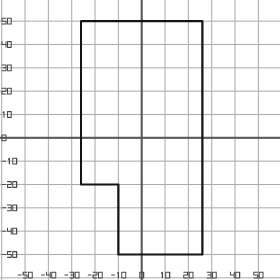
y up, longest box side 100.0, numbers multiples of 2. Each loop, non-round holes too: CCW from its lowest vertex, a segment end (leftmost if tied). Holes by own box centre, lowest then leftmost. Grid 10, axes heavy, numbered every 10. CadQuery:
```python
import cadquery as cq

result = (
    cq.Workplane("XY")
    .moveTo(-10.0, -50.0)
    .lineTo(26.0, -50.0)
    .lineTo(26.0, 50.0)
    .lineTo(-26.0, 50.0)
    .lineTo(-26.0, -20.0)
    .lineTo(-10.0, -20.0)
    .close()
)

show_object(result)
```